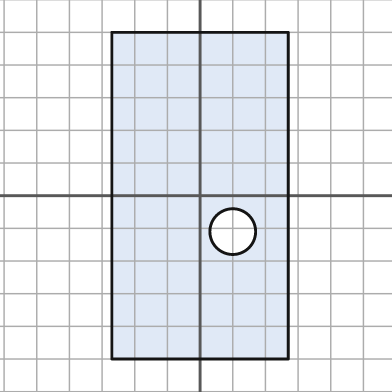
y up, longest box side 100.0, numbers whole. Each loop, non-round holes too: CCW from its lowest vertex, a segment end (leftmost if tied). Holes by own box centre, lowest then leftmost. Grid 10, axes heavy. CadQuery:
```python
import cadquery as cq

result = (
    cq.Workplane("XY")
    .moveTo(-27.0, -50.0)
    .lineTo(27.0, -50.0)
    .lineTo(27.0, 50.0)
    .lineTo(-27.0, 50.0)
    .close()
    .moveTo(10.0, -11.0)
    .circle(7.0)
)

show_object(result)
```